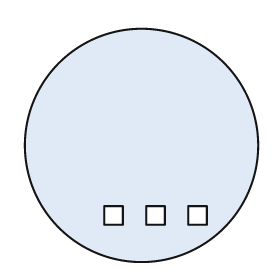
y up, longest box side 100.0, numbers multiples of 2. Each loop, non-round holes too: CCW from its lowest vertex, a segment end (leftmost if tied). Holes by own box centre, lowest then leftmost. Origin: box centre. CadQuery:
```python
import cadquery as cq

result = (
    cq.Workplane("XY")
    .moveTo(0.0, 0.0)
    .circle(50.0)
    .moveTo(-16.0, -34.0)
    .lineTo(-8.0, -34.0)
    .lineTo(-8.0, -26.0)
    .lineTo(-16.0, -26.0)
    .close()
    .moveTo(2.0, -34.0)
    .lineTo(10.0, -34.0)
    .lineTo(10.0, -26.0)
    .lineTo(2.0, -26.0)
    .close()
    .moveTo(20.0, -34.0)
    .lineTo(28.0, -34.0)
    .lineTo(28.0, -26.0)
    .lineTo(20.0, -26.0)
    .close()
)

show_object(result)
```